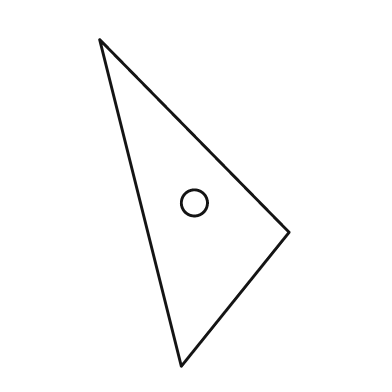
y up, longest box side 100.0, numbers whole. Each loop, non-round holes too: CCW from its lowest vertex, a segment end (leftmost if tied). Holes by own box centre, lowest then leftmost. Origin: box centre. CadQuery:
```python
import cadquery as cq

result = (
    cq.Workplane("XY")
    .moveTo(-4.0, -50.0)
    .lineTo(29.0, -9.0)
    .lineTo(-29.0, 50.0)
    .close()
    .moveTo(0.0, 0.0)
    .circle(4.0)
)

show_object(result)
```